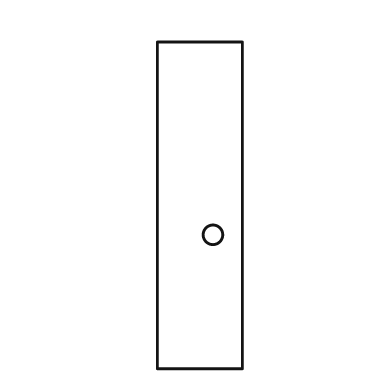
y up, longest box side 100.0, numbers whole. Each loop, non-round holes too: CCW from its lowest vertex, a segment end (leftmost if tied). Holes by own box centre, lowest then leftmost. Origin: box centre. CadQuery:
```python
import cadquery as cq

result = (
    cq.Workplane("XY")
    .moveTo(-13.0, -50.0)
    .lineTo(13.0, -50.0)
    .lineTo(13.0, 50.0)
    .lineTo(-13.0, 50.0)
    .close()
    .moveTo(4.0, -9.0)
    .circle(3.0)
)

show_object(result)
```